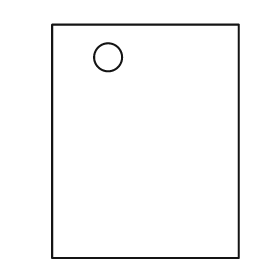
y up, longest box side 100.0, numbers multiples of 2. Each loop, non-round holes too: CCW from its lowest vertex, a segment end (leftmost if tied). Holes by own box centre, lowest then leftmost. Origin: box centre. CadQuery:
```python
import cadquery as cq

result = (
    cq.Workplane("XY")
    .moveTo(-40.0, -50.0)
    .lineTo(40.0, -50.0)
    .lineTo(40.0, 50.0)
    .lineTo(-40.0, 50.0)
    .close()
    .moveTo(-16.0, 36.0)
    .circle(6.0)
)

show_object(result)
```